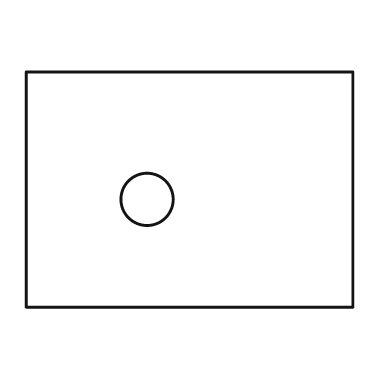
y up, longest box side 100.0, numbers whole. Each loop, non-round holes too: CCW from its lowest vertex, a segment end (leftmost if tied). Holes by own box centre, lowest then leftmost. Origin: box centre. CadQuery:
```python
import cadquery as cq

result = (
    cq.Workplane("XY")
    .moveTo(-50.0, -36.0)
    .lineTo(50.0, -36.0)
    .lineTo(50.0, 36.0)
    .lineTo(-50.0, 36.0)
    .close()
    .moveTo(-13.0, -3.0)
    .circle(8.0)
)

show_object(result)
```